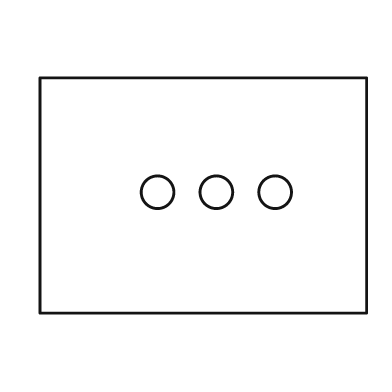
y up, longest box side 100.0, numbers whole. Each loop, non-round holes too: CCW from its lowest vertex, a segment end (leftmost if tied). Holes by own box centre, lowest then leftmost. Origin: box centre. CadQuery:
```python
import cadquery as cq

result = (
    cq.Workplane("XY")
    .moveTo(-50.0, -36.0)
    .lineTo(50.0, -36.0)
    .lineTo(50.0, 36.0)
    .lineTo(-50.0, 36.0)
    .close()
    .moveTo(-14.0, 1.0)
    .circle(5.0)
    .moveTo(4.0, 1.0)
    .circle(5.0)
    .moveTo(22.0, 1.0)
    .circle(5.0)
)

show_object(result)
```